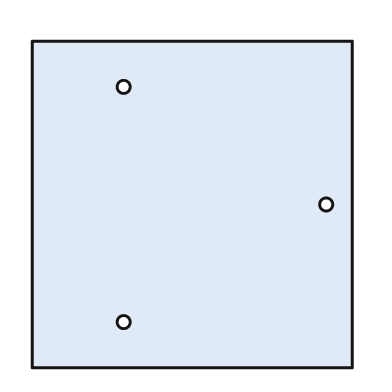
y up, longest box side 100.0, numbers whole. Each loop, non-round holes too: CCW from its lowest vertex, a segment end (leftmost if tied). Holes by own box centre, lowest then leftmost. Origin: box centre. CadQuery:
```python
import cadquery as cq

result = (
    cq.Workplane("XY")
    .moveTo(-49.0, -50.0)
    .lineTo(49.0, -50.0)
    .lineTo(49.0, 50.0)
    .lineTo(-49.0, 50.0)
    .close()
    .moveTo(-21.0, -36.0)
    .circle(2.0)
    .moveTo(41.0, 0.0)
    .circle(2.0)
    .moveTo(-21.0, 36.0)
    .circle(2.0)
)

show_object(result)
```